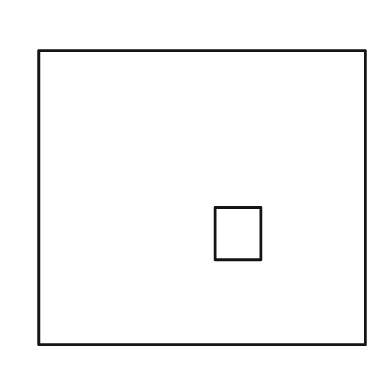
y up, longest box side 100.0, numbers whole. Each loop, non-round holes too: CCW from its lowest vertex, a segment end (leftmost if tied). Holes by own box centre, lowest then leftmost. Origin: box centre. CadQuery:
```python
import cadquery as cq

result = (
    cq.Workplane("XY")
    .moveTo(-50.0, -45.0)
    .lineTo(50.0, -45.0)
    .lineTo(50.0, 45.0)
    .lineTo(-50.0, 45.0)
    .close()
    .moveTo(4.0, -19.0)
    .lineTo(18.0, -19.0)
    .lineTo(18.0, -3.0)
    .lineTo(4.0, -3.0)
    .close()
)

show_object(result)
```